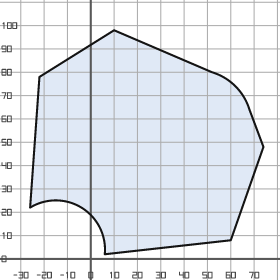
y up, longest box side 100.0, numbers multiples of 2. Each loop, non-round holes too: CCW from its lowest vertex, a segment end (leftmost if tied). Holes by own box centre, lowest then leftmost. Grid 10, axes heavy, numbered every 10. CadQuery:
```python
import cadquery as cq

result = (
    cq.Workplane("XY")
    .moveTo(6.0, 2.0)
    .lineTo(60.0, 8.0)
    .lineTo(74.0, 48.0)
    .lineTo(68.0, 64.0)
    .threePointArc((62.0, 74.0), (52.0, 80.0))
    .lineTo(10.0, 98.0)
    .lineTo(-22.0, 78.0)
    .lineTo(-26.0, 22.0)
    .threePointArc((-4.0, 22.0), (6.0, 2.0))
    .close()
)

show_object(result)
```